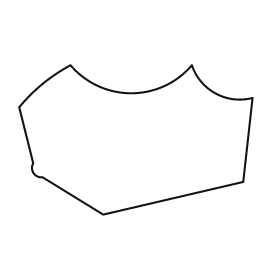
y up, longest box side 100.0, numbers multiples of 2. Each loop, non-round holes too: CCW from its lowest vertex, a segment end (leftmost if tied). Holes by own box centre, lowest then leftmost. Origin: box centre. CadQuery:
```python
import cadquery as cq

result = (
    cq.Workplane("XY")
    .moveTo(-14.0, -32.0)
    .lineTo(46.0, -18.0)
    .lineTo(50.0, 18.0)
    .threePointArc((34.0, 20.0), (24.0, 32.0))
    .threePointArc((-2.0, 20.0), (-28.0, 32.0))
    .threePointArc((-40.0, 24.0), (-50.0, 14.0))
    .lineTo(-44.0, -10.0)
    .threePointArc((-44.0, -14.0), (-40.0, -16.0))
    .close()
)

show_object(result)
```